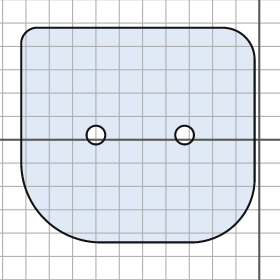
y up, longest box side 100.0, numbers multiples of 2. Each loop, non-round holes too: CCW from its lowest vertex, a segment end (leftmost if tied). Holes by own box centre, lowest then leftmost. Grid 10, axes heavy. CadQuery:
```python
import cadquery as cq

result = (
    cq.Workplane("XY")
    .moveTo(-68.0, -44.0)
    .lineTo(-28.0, -44.0)
    .threePointArc((-10.0, -36.0), (-2.0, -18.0))
    .lineTo(-2.0, 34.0)
    .threePointArc((-6.0, 44.0), (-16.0, 48.0))
    .lineTo(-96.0, 48.0)
    .threePointArc((-100.0, 46.0), (-102.0, 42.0))
    .lineTo(-102.0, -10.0)
    .threePointArc((-92.0, -34.0), (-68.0, -44.0))
    .close()
    .moveTo(-70.0, 2.0)
    .circle(4.0)
    .moveTo(-32.0, 2.0)
    .circle(4.0)
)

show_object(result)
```